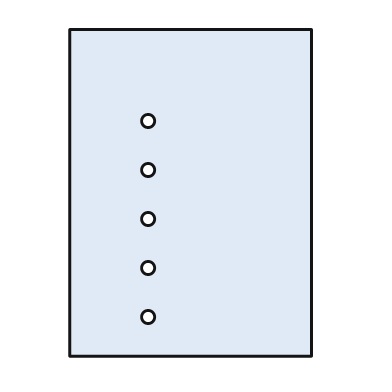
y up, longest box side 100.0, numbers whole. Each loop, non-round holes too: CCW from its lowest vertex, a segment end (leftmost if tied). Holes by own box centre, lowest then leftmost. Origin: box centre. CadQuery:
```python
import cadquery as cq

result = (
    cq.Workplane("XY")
    .moveTo(-37.0, -50.0)
    .lineTo(37.0, -50.0)
    .lineTo(37.0, 50.0)
    .lineTo(-37.0, 50.0)
    .close()
    .moveTo(-13.0, -38.0)
    .circle(2.0)
    .moveTo(-13.0, -23.0)
    .circle(2.0)
    .moveTo(-13.0, -8.0)
    .circle(2.0)
    .moveTo(-13.0, 7.0)
    .circle(2.0)
    .moveTo(-13.0, 22.0)
    .circle(2.0)
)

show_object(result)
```